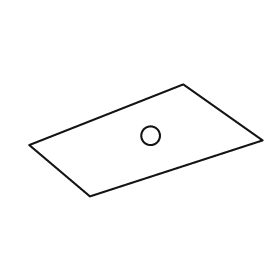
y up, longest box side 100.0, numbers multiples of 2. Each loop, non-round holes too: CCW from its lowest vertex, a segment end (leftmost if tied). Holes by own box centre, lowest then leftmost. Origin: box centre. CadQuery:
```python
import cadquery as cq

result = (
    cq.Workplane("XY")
    .moveTo(-24.0, -24.0)
    .lineTo(50.0, 0.0)
    .lineTo(16.0, 24.0)
    .lineTo(-50.0, -2.0)
    .close()
    .moveTo(2.0, 2.0)
    .circle(4.0)
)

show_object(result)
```